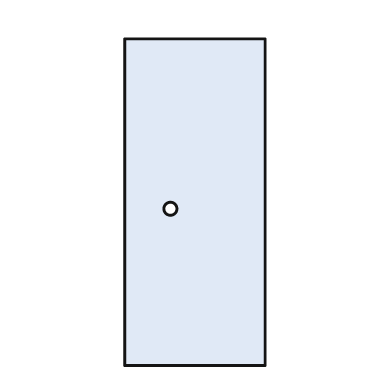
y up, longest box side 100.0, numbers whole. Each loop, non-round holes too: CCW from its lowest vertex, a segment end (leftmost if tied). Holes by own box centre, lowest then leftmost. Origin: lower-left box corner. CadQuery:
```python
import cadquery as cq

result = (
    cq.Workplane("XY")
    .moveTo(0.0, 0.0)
    .lineTo(43.0, 0.0)
    .lineTo(43.0, 100.0)
    .lineTo(0.0, 100.0)
    .close()
    .moveTo(14.0, 48.0)
    .circle(2.0)
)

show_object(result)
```